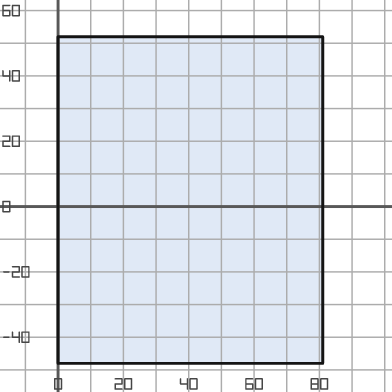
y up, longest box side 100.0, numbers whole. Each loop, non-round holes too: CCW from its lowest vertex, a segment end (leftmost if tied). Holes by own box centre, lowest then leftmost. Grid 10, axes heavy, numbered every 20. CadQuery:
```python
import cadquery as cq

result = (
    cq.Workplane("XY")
    .moveTo(0.0, -48.0)
    .lineTo(81.0, -48.0)
    .lineTo(81.0, 52.0)
    .lineTo(0.0, 52.0)
    .close()
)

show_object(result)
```